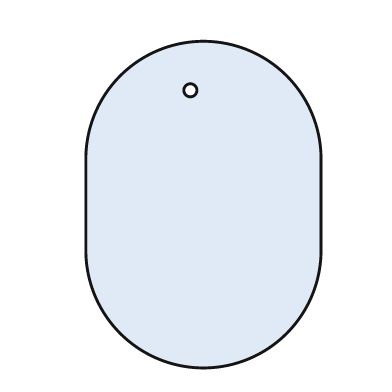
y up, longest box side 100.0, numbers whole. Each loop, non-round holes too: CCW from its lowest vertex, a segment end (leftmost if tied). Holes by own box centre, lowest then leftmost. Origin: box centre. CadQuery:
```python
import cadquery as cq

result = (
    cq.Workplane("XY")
    .moveTo(-36.0, -14.0)
    .threePointArc((0.0, -50.0), (36.0, -14.0))
    .lineTo(36.0, 14.0)
    .threePointArc((0.0, 50.0), (-36.0, 14.0))
    .close()
    .moveTo(-4.0, 35.0)
    .circle(2.0)
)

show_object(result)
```